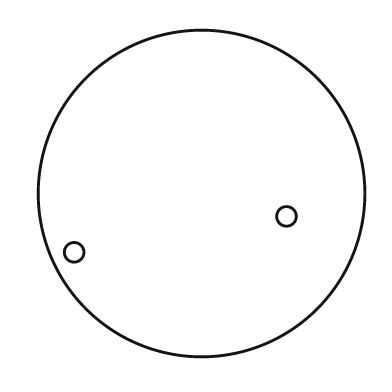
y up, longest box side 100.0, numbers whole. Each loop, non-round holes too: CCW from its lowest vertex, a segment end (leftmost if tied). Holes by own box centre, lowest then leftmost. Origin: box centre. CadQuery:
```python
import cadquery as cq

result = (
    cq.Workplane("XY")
    .moveTo(0.0, 0.0)
    .circle(50.0)
    .moveTo(-39.0, -18.0)
    .circle(3.0)
    .moveTo(26.0, -7.0)
    .circle(3.0)
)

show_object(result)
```